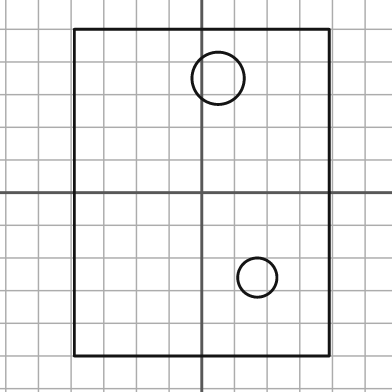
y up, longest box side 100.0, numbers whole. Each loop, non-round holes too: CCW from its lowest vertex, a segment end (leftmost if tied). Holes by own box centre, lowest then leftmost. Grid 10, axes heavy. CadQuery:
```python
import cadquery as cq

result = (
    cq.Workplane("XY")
    .moveTo(-39.0, -50.0)
    .lineTo(39.0, -50.0)
    .lineTo(39.0, 50.0)
    .lineTo(-39.0, 50.0)
    .close()
    .moveTo(17.0, -26.0)
    .circle(6.0)
    .moveTo(5.0, 35.0)
    .circle(8.0)
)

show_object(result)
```